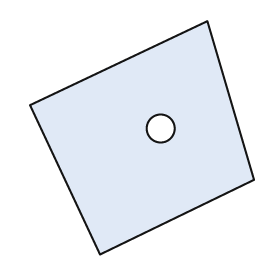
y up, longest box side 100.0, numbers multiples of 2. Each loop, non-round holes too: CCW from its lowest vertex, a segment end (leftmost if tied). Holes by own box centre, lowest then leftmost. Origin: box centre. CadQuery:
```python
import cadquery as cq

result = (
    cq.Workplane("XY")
    .moveTo(-18.0, -50.0)
    .lineTo(48.0, -18.0)
    .lineTo(28.0, 50.0)
    .lineTo(-48.0, 14.0)
    .close()
    .moveTo(8.0, 4.0)
    .circle(6.0)
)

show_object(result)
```